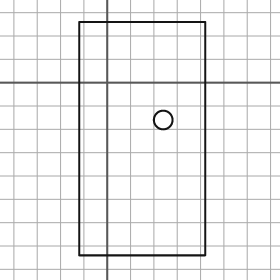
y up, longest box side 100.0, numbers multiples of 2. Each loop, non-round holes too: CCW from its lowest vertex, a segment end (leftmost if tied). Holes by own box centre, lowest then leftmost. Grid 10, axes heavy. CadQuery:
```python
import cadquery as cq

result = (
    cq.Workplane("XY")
    .moveTo(-12.0, -74.0)
    .lineTo(42.0, -74.0)
    .lineTo(42.0, 26.0)
    .lineTo(-12.0, 26.0)
    .close()
    .moveTo(24.0, -16.0)
    .circle(4.0)
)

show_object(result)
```